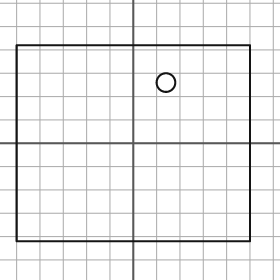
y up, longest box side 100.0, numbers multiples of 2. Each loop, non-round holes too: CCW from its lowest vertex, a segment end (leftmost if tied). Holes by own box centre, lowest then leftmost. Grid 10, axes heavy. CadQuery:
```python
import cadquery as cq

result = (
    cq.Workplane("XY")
    .moveTo(-50.0, -42.0)
    .lineTo(50.0, -42.0)
    .lineTo(50.0, 42.0)
    .lineTo(-50.0, 42.0)
    .close()
    .moveTo(14.0, 26.0)
    .circle(4.0)
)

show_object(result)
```